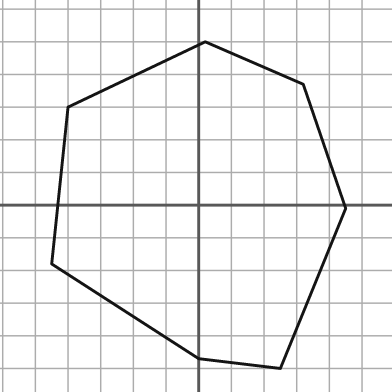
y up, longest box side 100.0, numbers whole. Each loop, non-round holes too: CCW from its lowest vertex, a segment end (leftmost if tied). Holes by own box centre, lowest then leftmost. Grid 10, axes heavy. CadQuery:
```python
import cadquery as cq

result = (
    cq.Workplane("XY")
    .moveTo(25.0, -50.0)
    .lineTo(45.0, -1.0)
    .lineTo(32.0, 37.0)
    .lineTo(2.0, 50.0)
    .lineTo(-40.0, 30.0)
    .lineTo(-45.0, -18.0)
    .lineTo(0.0, -47.0)
    .close()
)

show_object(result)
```